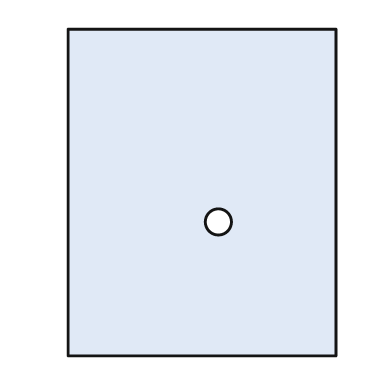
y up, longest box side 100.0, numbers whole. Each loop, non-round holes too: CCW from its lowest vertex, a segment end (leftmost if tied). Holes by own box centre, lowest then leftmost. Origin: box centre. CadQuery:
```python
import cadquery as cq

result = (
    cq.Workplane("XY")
    .moveTo(-41.0, -50.0)
    .lineTo(41.0, -50.0)
    .lineTo(41.0, 50.0)
    .lineTo(-41.0, 50.0)
    .close()
    .moveTo(5.0, -9.0)
    .circle(4.0)
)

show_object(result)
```